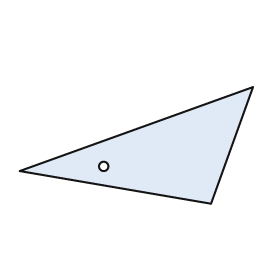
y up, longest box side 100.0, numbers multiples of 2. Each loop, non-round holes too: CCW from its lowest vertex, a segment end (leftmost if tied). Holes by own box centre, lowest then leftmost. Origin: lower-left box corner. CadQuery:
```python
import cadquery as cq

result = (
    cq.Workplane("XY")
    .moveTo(82.0, 0.0)
    .lineTo(100.0, 50.0)
    .lineTo(0.0, 14.0)
    .close()
    .moveTo(36.0, 16.0)
    .circle(2.0)
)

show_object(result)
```